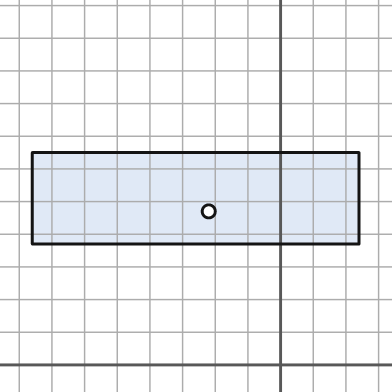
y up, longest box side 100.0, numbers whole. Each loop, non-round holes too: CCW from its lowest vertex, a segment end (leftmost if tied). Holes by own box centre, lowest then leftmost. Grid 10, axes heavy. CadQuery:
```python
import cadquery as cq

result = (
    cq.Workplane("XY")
    .moveTo(-76.0, 37.0)
    .lineTo(24.0, 37.0)
    .lineTo(24.0, 65.0)
    .lineTo(-76.0, 65.0)
    .close()
    .moveTo(-22.0, 47.0)
    .circle(2.0)
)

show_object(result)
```